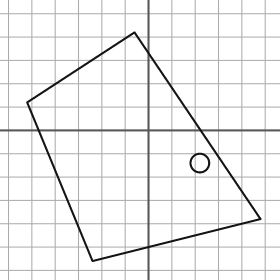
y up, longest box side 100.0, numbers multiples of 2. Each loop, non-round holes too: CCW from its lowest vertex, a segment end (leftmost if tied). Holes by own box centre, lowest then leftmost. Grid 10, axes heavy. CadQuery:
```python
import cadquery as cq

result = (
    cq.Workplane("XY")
    .moveTo(-24.0, -56.0)
    .lineTo(48.0, -38.0)
    .lineTo(-6.0, 42.0)
    .lineTo(-52.0, 12.0)
    .close()
    .moveTo(22.0, -14.0)
    .circle(4.0)
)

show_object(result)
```